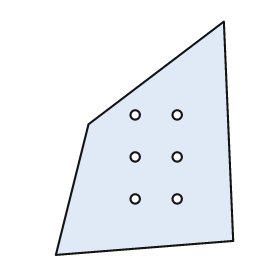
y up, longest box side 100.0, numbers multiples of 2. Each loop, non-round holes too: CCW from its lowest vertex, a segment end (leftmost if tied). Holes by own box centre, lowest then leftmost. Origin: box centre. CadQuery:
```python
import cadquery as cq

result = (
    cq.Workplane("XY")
    .moveTo(-38.0, -50.0)
    .lineTo(38.0, -44.0)
    .lineTo(34.0, 50.0)
    .lineTo(-24.0, 6.0)
    .close()
    .moveTo(-4.0, -26.0)
    .circle(2.0)
    .moveTo(14.0, -26.0)
    .circle(2.0)
    .moveTo(-4.0, -8.0)
    .circle(2.0)
    .moveTo(14.0, -8.0)
    .circle(2.0)
    .moveTo(-4.0, 10.0)
    .circle(2.0)
    .moveTo(14.0, 10.0)
    .circle(2.0)
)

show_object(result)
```